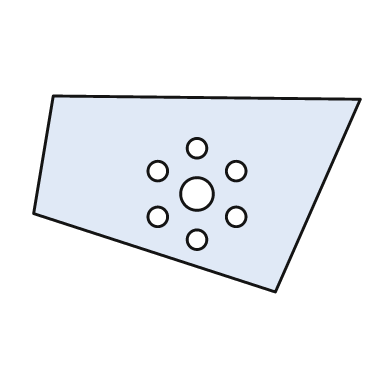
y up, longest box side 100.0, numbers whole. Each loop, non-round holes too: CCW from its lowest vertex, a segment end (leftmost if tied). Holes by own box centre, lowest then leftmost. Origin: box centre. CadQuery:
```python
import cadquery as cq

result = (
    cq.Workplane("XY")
    .moveTo(24.0, -30.0)
    .lineTo(50.0, 29.0)
    .lineTo(-44.0, 30.0)
    .lineTo(-50.0, -6.0)
    .close()
    .moveTo(0.0, -14.0)
    .circle(3.0)
    .moveTo(-12.0, -7.0)
    .circle(3.0)
    .moveTo(12.0, -7.0)
    .circle(3.0)
    .moveTo(0.0, 0.0)
    .circle(5.0)
    .moveTo(-12.0, 7.0)
    .circle(3.0)
    .moveTo(12.0, 7.0)
    .circle(3.0)
    .moveTo(0.0, 14.0)
    .circle(3.0)
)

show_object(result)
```